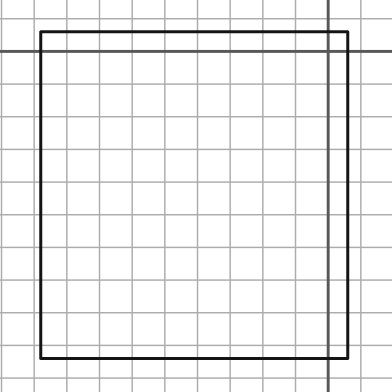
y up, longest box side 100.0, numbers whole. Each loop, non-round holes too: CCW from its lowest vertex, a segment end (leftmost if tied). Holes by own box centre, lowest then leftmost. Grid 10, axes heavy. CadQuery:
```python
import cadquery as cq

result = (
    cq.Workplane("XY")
    .moveTo(-88.0, -94.0)
    .lineTo(6.0, -94.0)
    .lineTo(6.0, 6.0)
    .lineTo(-88.0, 6.0)
    .close()
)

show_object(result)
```